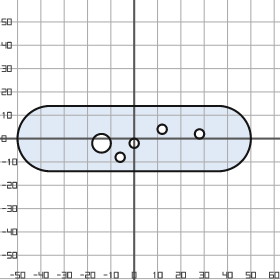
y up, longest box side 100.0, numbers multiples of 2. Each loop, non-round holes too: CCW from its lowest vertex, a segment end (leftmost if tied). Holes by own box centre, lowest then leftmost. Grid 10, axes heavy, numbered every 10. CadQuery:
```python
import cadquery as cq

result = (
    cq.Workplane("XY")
    .moveTo(-36.0, -14.0)
    .lineTo(36.0, -14.0)
    .threePointArc((50.0, 0.0), (36.0, 14.0))
    .lineTo(-36.0, 14.0)
    .threePointArc((-50.0, 0.0), (-36.0, -14.0))
    .close()
    .moveTo(-6.0, -8.0)
    .circle(2.0)
    .moveTo(-14.0, -2.0)
    .circle(4.0)
    .moveTo(0.0, -2.0)
    .circle(2.0)
    .moveTo(28.0, 2.0)
    .circle(2.0)
    .moveTo(12.0, 4.0)
    .circle(2.0)
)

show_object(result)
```